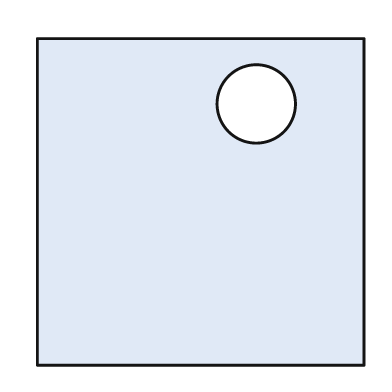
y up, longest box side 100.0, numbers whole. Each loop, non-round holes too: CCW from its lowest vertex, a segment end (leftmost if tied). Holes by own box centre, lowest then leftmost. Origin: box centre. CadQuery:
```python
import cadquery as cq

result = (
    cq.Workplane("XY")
    .moveTo(-50.0, -50.0)
    .lineTo(50.0, -50.0)
    .lineTo(50.0, 50.0)
    .lineTo(-50.0, 50.0)
    .close()
    .moveTo(17.0, 30.0)
    .circle(12.0)
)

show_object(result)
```